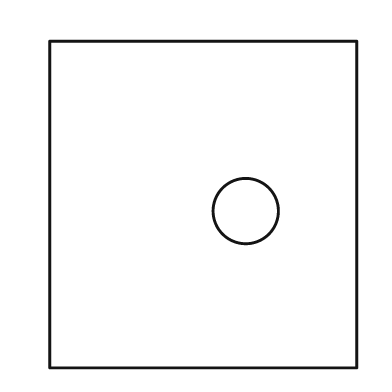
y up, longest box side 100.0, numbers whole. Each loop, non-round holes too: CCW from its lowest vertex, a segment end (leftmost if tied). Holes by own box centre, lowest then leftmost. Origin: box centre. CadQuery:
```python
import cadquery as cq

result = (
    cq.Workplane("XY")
    .moveTo(-47.0, -50.0)
    .lineTo(47.0, -50.0)
    .lineTo(47.0, 50.0)
    .lineTo(-47.0, 50.0)
    .close()
    .moveTo(13.0, -2.0)
    .circle(10.0)
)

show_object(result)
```